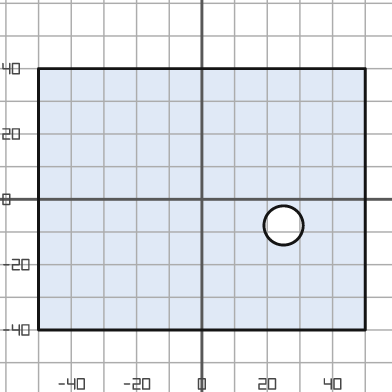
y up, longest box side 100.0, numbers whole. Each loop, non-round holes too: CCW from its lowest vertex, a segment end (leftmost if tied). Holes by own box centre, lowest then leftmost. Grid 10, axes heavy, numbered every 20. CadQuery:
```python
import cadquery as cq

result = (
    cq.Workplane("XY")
    .moveTo(-50.0, -40.0)
    .lineTo(50.0, -40.0)
    .lineTo(50.0, 40.0)
    .lineTo(-50.0, 40.0)
    .close()
    .moveTo(25.0, -8.0)
    .circle(6.0)
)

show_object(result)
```